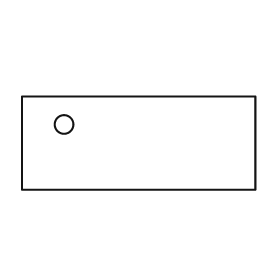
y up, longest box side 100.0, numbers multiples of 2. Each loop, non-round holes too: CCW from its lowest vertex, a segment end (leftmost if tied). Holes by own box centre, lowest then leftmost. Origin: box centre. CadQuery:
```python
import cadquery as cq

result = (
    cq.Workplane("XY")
    .moveTo(-50.0, -20.0)
    .lineTo(50.0, -20.0)
    .lineTo(50.0, 20.0)
    .lineTo(-50.0, 20.0)
    .close()
    .moveTo(-32.0, 8.0)
    .circle(4.0)
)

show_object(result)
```